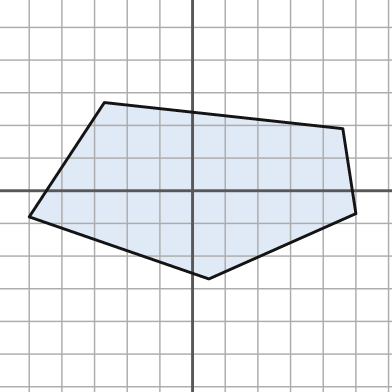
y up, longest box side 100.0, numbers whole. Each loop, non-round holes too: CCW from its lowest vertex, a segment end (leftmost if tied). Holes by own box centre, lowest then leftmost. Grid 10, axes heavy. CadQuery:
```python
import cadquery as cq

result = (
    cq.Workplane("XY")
    .moveTo(5.0, -27.0)
    .lineTo(50.0, -7.0)
    .lineTo(46.0, 19.0)
    .lineTo(-27.0, 27.0)
    .lineTo(-50.0, -8.0)
    .close()
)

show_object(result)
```